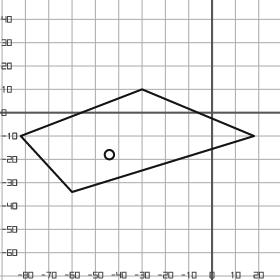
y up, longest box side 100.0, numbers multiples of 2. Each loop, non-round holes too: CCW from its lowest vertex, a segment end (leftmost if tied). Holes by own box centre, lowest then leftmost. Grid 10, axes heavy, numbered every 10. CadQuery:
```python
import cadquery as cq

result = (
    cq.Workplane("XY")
    .moveTo(-60.0, -34.0)
    .lineTo(18.0, -10.0)
    .lineTo(-30.0, 10.0)
    .lineTo(-82.0, -10.0)
    .close()
    .moveTo(-44.0, -18.0)
    .circle(2.0)
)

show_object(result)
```